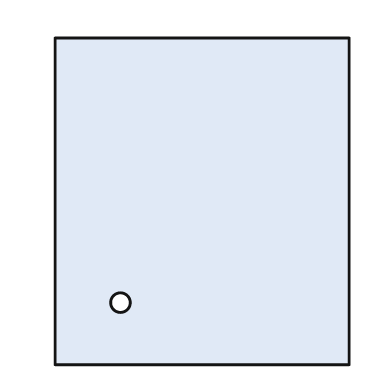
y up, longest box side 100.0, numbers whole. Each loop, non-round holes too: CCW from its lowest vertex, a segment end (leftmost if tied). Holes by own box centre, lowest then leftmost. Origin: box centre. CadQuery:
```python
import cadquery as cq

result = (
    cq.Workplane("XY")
    .moveTo(-45.0, -50.0)
    .lineTo(45.0, -50.0)
    .lineTo(45.0, 50.0)
    .lineTo(-45.0, 50.0)
    .close()
    .moveTo(-25.0, -31.0)
    .circle(3.0)
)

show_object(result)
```